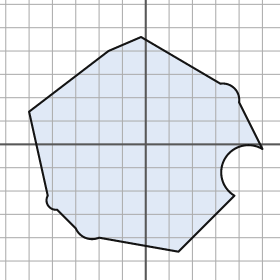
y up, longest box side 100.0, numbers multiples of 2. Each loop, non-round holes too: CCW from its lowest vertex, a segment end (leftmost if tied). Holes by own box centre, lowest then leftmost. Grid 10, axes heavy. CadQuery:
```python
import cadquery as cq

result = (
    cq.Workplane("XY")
    .moveTo(14.0, -46.0)
    .lineTo(38.0, -22.0)
    .threePointArc((34.0, -6.0), (50.0, -2.0))
    .lineTo(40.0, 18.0)
    .threePointArc((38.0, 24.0), (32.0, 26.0))
    .lineTo(-2.0, 46.0)
    .lineTo(-16.0, 40.0)
    .lineTo(-50.0, 14.0)
    .lineTo(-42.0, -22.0)
    .threePointArc((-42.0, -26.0), (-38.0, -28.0))
    .lineTo(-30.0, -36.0)
    .threePointArc((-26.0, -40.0), (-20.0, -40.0))
    .close()
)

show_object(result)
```